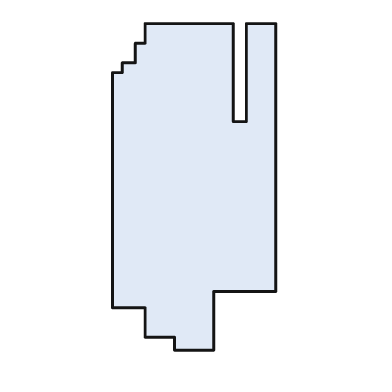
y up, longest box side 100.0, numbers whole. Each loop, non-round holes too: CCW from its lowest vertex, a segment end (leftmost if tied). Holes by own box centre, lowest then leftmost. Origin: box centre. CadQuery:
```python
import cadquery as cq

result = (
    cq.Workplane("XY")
    .moveTo(-6.0, -50.0)
    .lineTo(6.0, -50.0)
    .lineTo(6.0, -32.0)
    .lineTo(25.0, -32.0)
    .lineTo(25.0, 50.0)
    .lineTo(16.0, 50.0)
    .lineTo(16.0, 20.0)
    .lineTo(12.0, 20.0)
    .lineTo(12.0, 50.0)
    .lineTo(-15.0, 50.0)
    .lineTo(-15.0, 44.0)
    .lineTo(-18.0, 44.0)
    .lineTo(-18.0, 38.0)
    .lineTo(-22.0, 38.0)
    .lineTo(-22.0, 35.0)
    .lineTo(-25.0, 35.0)
    .lineTo(-25.0, -37.0)
    .lineTo(-15.0, -37.0)
    .lineTo(-15.0, -46.0)
    .lineTo(-6.0, -46.0)
    .close()
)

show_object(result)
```